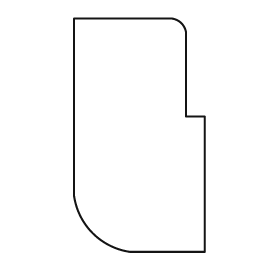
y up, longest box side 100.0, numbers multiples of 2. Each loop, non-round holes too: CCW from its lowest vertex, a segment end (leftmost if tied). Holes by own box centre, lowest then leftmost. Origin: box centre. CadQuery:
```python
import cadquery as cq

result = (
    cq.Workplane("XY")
    .moveTo(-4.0, -50.0)
    .lineTo(28.0, -50.0)
    .lineTo(28.0, 8.0)
    .lineTo(20.0, 8.0)
    .lineTo(20.0, 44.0)
    .threePointArc((18.0, 48.0), (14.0, 50.0))
    .lineTo(-28.0, 50.0)
    .lineTo(-28.0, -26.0)
    .threePointArc((-20.0, -42.0), (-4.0, -50.0))
    .close()
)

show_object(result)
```